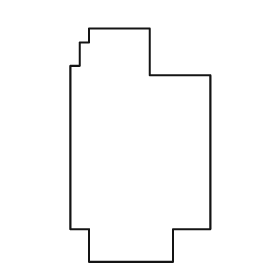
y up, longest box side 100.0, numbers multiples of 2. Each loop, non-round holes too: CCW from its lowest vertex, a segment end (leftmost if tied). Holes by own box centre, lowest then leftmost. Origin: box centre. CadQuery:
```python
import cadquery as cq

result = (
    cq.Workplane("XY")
    .moveTo(-22.0, -50.0)
    .lineTo(14.0, -50.0)
    .lineTo(14.0, -36.0)
    .lineTo(30.0, -36.0)
    .lineTo(30.0, 30.0)
    .lineTo(4.0, 30.0)
    .lineTo(4.0, 50.0)
    .lineTo(-22.0, 50.0)
    .lineTo(-22.0, 44.0)
    .lineTo(-26.0, 44.0)
    .lineTo(-26.0, 34.0)
    .lineTo(-30.0, 34.0)
    .lineTo(-30.0, -36.0)
    .lineTo(-22.0, -36.0)
    .close()
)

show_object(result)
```